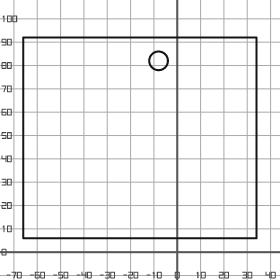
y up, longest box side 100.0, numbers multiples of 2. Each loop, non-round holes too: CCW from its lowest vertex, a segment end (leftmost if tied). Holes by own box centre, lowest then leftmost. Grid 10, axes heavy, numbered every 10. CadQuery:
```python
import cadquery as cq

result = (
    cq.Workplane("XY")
    .moveTo(-66.0, 6.0)
    .lineTo(34.0, 6.0)
    .lineTo(34.0, 92.0)
    .lineTo(-66.0, 92.0)
    .close()
    .moveTo(-8.0, 82.0)
    .circle(4.0)
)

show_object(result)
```